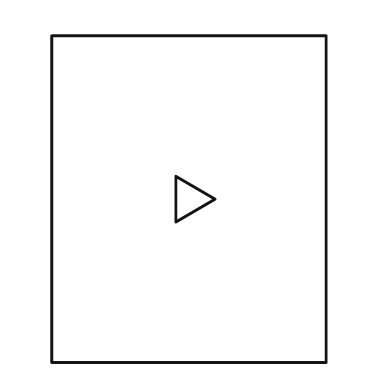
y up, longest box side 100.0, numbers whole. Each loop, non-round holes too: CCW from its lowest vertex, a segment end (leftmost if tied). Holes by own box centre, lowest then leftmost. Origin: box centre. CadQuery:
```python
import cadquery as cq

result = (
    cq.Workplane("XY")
    .moveTo(-42.0, -50.0)
    .lineTo(42.0, -50.0)
    .lineTo(42.0, 50.0)
    .lineTo(-42.0, 50.0)
    .close()
    .moveTo(-4.0, -7.0)
    .lineTo(8.0, 0.0)
    .lineTo(-4.0, 7.0)
    .close()
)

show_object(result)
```